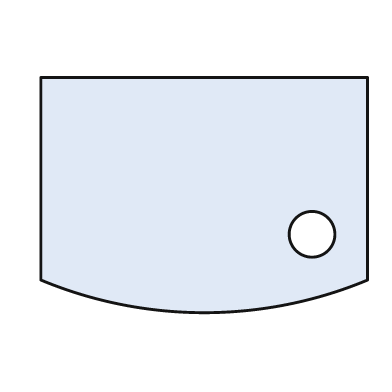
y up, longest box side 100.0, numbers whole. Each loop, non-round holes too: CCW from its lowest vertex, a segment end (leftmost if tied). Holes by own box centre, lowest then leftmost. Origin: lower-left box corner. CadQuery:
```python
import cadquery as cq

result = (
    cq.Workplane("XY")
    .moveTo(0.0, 10.0)
    .threePointArc((50.0, 0.0), (100.0, 10.0))
    .lineTo(100.0, 72.0)
    .lineTo(0.0, 72.0)
    .close()
    .moveTo(83.0, 24.0)
    .circle(7.0)
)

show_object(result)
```